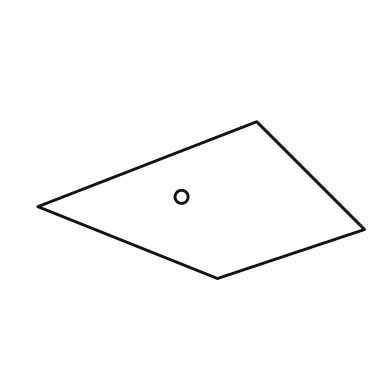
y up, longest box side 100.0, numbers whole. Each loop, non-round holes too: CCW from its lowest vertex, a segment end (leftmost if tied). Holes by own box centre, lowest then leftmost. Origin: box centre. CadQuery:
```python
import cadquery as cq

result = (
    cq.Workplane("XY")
    .moveTo(5.0, -24.0)
    .lineTo(50.0, -9.0)
    .lineTo(17.0, 24.0)
    .lineTo(-50.0, -2.0)
    .close()
    .moveTo(-6.0, 1.0)
    .circle(2.0)
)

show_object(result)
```